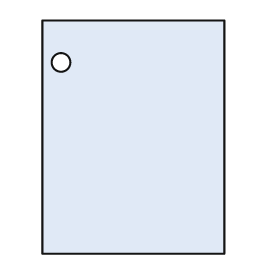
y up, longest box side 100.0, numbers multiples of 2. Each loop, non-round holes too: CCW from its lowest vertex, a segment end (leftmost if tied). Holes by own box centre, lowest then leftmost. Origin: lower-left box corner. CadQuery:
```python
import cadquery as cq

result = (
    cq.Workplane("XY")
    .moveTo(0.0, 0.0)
    .lineTo(78.0, 0.0)
    .lineTo(78.0, 100.0)
    .lineTo(0.0, 100.0)
    .close()
    .moveTo(8.0, 82.0)
    .circle(4.0)
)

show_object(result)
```